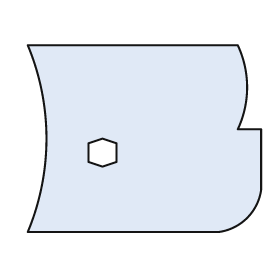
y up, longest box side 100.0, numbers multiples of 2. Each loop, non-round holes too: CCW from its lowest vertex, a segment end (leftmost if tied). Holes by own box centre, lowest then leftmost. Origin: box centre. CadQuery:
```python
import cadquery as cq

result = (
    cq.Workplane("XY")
    .moveTo(-50.0, -40.0)
    .lineTo(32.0, -40.0)
    .threePointArc((44.0, -34.0), (50.0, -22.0))
    .lineTo(50.0, 4.0)
    .lineTo(40.0, 4.0)
    .threePointArc((44.0, 22.0), (40.0, 40.0))
    .lineTo(-50.0, 40.0)
    .threePointArc((-42.0, 0.0), (-50.0, -40.0))
    .close()
    .moveTo(-18.0, -12.0)
    .lineTo(-12.0, -10.0)
    .lineTo(-12.0, -2.0)
    .lineTo(-18.0, 0.0)
    .lineTo(-24.0, -2.0)
    .lineTo(-24.0, -10.0)
    .close()
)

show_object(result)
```